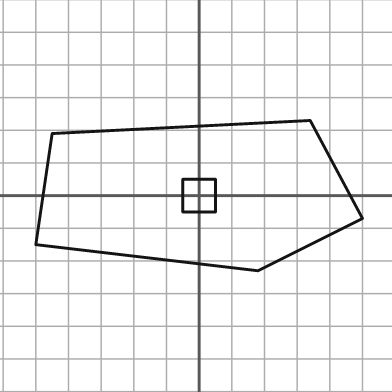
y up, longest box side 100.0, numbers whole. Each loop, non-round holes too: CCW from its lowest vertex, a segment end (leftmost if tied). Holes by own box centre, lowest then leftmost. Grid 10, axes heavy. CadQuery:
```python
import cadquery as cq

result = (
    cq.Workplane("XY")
    .moveTo(18.0, -23.0)
    .lineTo(50.0, -7.0)
    .lineTo(34.0, 23.0)
    .lineTo(-45.0, 19.0)
    .lineTo(-50.0, -15.0)
    .close()
    .moveTo(-5.0, -5.0)
    .lineTo(5.0, -5.0)
    .lineTo(5.0, 5.0)
    .lineTo(-5.0, 5.0)
    .close()
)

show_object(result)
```